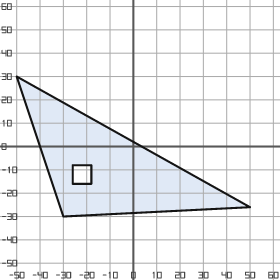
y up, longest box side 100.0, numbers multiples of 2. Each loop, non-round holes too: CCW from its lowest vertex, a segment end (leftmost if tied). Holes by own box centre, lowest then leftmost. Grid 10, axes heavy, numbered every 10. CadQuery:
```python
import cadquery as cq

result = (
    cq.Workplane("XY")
    .moveTo(-30.0, -30.0)
    .lineTo(50.0, -26.0)
    .lineTo(-50.0, 30.0)
    .close()
    .moveTo(-26.0, -16.0)
    .lineTo(-18.0, -16.0)
    .lineTo(-18.0, -8.0)
    .lineTo(-26.0, -8.0)
    .close()
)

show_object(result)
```